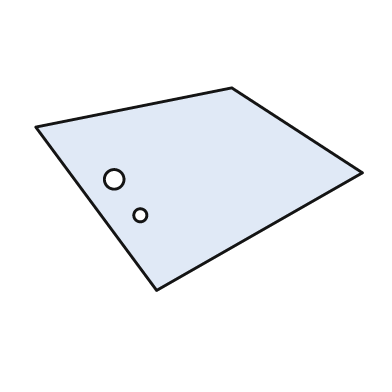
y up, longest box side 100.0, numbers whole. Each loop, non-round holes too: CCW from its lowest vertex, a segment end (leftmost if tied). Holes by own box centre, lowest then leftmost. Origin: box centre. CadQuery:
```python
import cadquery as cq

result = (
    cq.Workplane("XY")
    .moveTo(-13.0, -31.0)
    .lineTo(50.0, 5.0)
    .lineTo(10.0, 31.0)
    .lineTo(-50.0, 19.0)
    .close()
    .moveTo(-18.0, -8.0)
    .circle(2.0)
    .moveTo(-26.0, 3.0)
    .circle(3.0)
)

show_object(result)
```